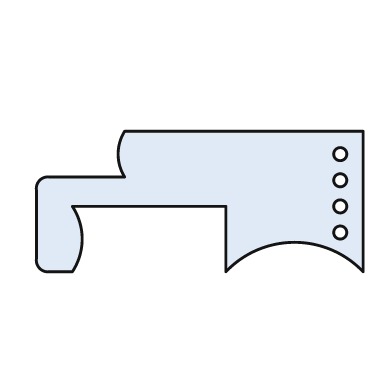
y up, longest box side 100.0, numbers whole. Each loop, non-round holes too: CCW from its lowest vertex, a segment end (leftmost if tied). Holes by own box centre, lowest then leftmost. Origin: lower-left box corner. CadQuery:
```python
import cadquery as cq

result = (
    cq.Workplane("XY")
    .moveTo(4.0, 0.0)
    .lineTo(11.0, 0.0)
    .threePointArc((14.0, 10.0), (11.0, 20.0))
    .lineTo(58.0, 20.0)
    .lineTo(58.0, 0.0)
    .threePointArc((79.0, 9.0), (100.0, 0.0))
    .lineTo(100.0, 43.0)
    .lineTo(27.0, 43.0)
    .threePointArc((25.0, 36.0), (27.0, 29.0))
    .lineTo(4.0, 29.0)
    .threePointArc((1.0, 28.0), (0.0, 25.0))
    .lineTo(0.0, 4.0)
    .threePointArc((1.0, 1.0), (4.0, 0.0))
    .close()
    .moveTo(93.0, 12.0)
    .circle(2.0)
    .moveTo(93.0, 20.0)
    .circle(2.0)
    .moveTo(93.0, 28.0)
    .circle(2.0)
    .moveTo(93.0, 36.0)
    .circle(2.0)
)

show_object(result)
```